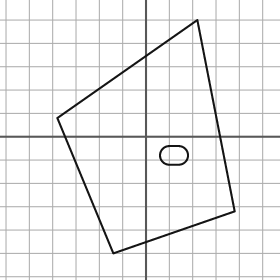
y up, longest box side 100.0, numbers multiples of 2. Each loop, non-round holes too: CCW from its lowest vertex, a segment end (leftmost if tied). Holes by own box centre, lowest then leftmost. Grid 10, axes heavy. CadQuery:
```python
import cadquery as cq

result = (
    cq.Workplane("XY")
    .moveTo(-14.0, -50.0)
    .lineTo(38.0, -32.0)
    .lineTo(22.0, 50.0)
    .lineTo(-38.0, 8.0)
    .close()
    .moveTo(10.0, -12.0)
    .lineTo(14.0, -12.0)
    .threePointArc((18.0, -8.0), (14.0, -4.0))
    .lineTo(10.0, -4.0)
    .threePointArc((6.0, -8.0), (10.0, -12.0))
    .close()
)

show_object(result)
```